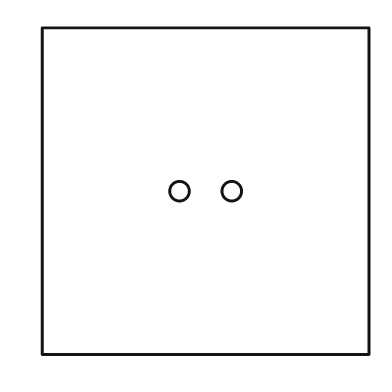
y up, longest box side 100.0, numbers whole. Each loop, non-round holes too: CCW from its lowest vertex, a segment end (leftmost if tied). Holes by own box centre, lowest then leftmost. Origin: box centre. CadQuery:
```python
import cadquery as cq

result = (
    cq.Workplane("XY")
    .moveTo(-50.0, -50.0)
    .lineTo(50.0, -50.0)
    .lineTo(50.0, 50.0)
    .lineTo(-50.0, 50.0)
    .close()
    .moveTo(-8.0, 0.0)
    .circle(3.0)
    .moveTo(8.0, 0.0)
    .circle(3.0)
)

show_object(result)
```